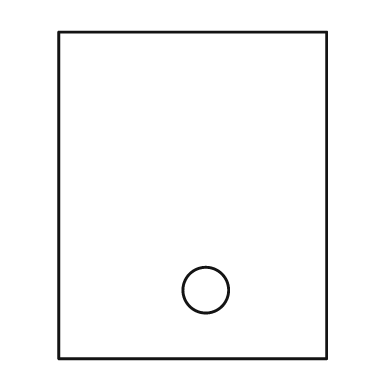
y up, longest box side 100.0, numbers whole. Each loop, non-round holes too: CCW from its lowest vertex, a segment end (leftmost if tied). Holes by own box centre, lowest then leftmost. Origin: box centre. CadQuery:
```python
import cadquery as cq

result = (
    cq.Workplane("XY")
    .moveTo(-41.0, -50.0)
    .lineTo(41.0, -50.0)
    .lineTo(41.0, 50.0)
    .lineTo(-41.0, 50.0)
    .close()
    .moveTo(4.0, -29.0)
    .circle(7.0)
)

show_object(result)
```